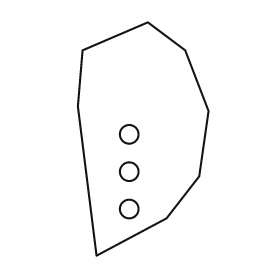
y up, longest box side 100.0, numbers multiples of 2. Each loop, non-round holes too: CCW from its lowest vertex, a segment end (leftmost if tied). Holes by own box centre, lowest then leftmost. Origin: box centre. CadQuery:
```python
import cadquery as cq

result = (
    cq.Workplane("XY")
    .moveTo(-20.0, -50.0)
    .lineTo(10.0, -34.0)
    .lineTo(24.0, -16.0)
    .lineTo(28.0, 12.0)
    .lineTo(18.0, 38.0)
    .lineTo(2.0, 50.0)
    .lineTo(-26.0, 38.0)
    .lineTo(-28.0, 14.0)
    .close()
    .moveTo(-6.0, -30.0)
    .circle(4.0)
    .moveTo(-6.0, -14.0)
    .circle(4.0)
    .moveTo(-6.0, 2.0)
    .circle(4.0)
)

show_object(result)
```